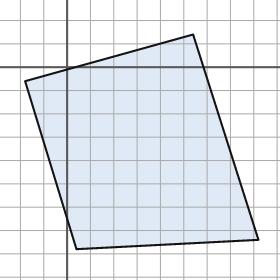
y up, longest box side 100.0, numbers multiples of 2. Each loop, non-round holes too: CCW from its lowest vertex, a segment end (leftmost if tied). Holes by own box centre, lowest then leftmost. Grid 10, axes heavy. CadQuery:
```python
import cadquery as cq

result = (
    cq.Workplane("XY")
    .moveTo(4.0, -78.0)
    .lineTo(82.0, -74.0)
    .lineTo(54.0, 14.0)
    .lineTo(-18.0, -6.0)
    .close()
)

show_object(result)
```